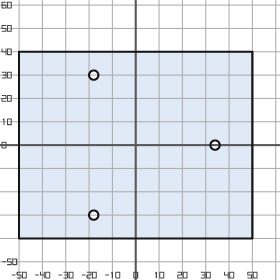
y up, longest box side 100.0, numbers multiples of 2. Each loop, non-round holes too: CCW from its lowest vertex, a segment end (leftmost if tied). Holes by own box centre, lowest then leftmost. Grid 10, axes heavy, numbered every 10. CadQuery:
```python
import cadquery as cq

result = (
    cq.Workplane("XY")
    .moveTo(-50.0, -40.0)
    .lineTo(50.0, -40.0)
    .lineTo(50.0, 40.0)
    .lineTo(-50.0, 40.0)
    .close()
    .moveTo(-18.0, -30.0)
    .circle(2.0)
    .moveTo(34.0, 0.0)
    .circle(2.0)
    .moveTo(-18.0, 30.0)
    .circle(2.0)
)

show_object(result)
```